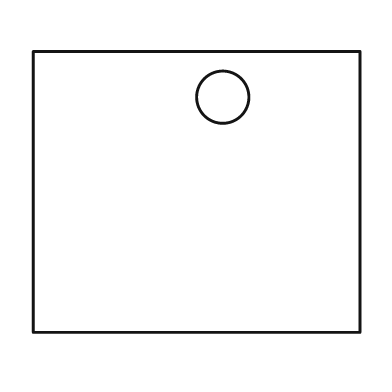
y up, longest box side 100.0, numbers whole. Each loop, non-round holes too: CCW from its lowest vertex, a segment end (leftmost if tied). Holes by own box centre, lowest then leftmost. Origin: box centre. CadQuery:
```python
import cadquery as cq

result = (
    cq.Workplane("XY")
    .moveTo(-50.0, -43.0)
    .lineTo(50.0, -43.0)
    .lineTo(50.0, 43.0)
    .lineTo(-50.0, 43.0)
    .close()
    .moveTo(8.0, 29.0)
    .circle(8.0)
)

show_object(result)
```